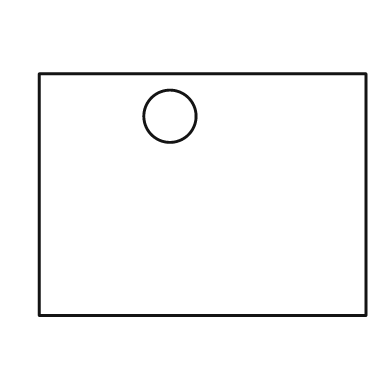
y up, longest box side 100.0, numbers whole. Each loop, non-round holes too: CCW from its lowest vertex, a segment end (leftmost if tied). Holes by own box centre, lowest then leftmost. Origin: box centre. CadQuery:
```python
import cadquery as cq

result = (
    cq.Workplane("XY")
    .moveTo(-50.0, -37.0)
    .lineTo(50.0, -37.0)
    .lineTo(50.0, 37.0)
    .lineTo(-50.0, 37.0)
    .close()
    .moveTo(-10.0, 24.0)
    .circle(8.0)
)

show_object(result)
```